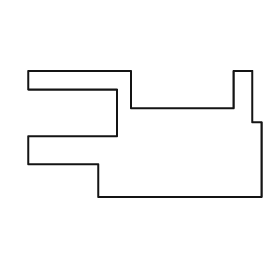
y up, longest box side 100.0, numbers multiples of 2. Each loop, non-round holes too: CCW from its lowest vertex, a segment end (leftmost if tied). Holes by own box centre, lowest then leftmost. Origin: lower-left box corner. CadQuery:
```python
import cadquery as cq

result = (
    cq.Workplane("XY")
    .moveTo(30.0, 0.0)
    .lineTo(100.0, 0.0)
    .lineTo(100.0, 32.0)
    .lineTo(96.0, 32.0)
    .lineTo(96.0, 54.0)
    .lineTo(88.0, 54.0)
    .lineTo(88.0, 38.0)
    .lineTo(44.0, 38.0)
    .lineTo(44.0, 54.0)
    .lineTo(0.0, 54.0)
    .lineTo(0.0, 46.0)
    .lineTo(38.0, 46.0)
    .lineTo(38.0, 26.0)
    .lineTo(0.0, 26.0)
    .lineTo(0.0, 14.0)
    .lineTo(30.0, 14.0)
    .close()
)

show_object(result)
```